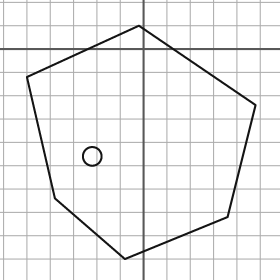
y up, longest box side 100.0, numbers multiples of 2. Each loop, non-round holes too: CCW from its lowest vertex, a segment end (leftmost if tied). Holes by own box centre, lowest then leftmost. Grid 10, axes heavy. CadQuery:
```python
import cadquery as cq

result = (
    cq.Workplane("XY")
    .moveTo(-8.0, -90.0)
    .lineTo(36.0, -72.0)
    .lineTo(48.0, -24.0)
    .lineTo(-2.0, 10.0)
    .lineTo(-50.0, -12.0)
    .lineTo(-38.0, -64.0)
    .close()
    .moveTo(-22.0, -46.0)
    .circle(4.0)
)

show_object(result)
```